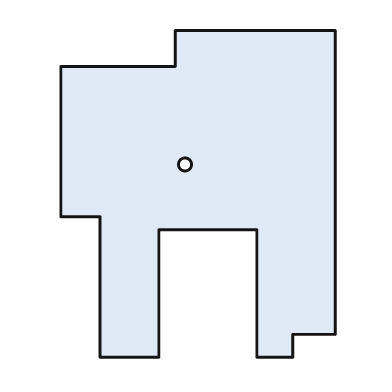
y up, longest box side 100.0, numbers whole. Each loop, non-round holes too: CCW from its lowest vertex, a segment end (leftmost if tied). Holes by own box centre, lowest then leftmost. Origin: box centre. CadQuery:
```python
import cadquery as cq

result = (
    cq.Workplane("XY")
    .moveTo(-30.0, -50.0)
    .lineTo(-12.0, -50.0)
    .lineTo(-12.0, -11.0)
    .lineTo(18.0, -11.0)
    .lineTo(18.0, -50.0)
    .lineTo(29.0, -50.0)
    .lineTo(29.0, -43.0)
    .lineTo(42.0, -43.0)
    .lineTo(42.0, 50.0)
    .lineTo(-7.0, 50.0)
    .lineTo(-7.0, 39.0)
    .lineTo(-42.0, 39.0)
    .lineTo(-42.0, -7.0)
    .lineTo(-30.0, -7.0)
    .close()
    .moveTo(-4.0, 9.0)
    .circle(2.0)
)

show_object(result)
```